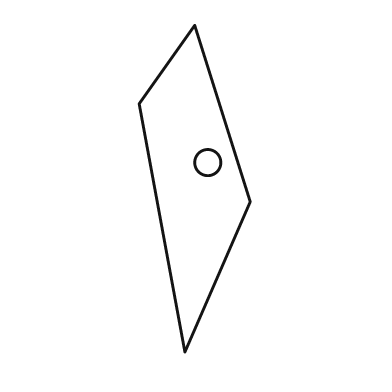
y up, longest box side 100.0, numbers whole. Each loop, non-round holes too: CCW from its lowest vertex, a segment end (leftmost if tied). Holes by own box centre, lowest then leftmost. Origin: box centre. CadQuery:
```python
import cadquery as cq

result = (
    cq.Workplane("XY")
    .moveTo(-3.0, -50.0)
    .lineTo(17.0, -4.0)
    .lineTo(0.0, 50.0)
    .lineTo(-17.0, 26.0)
    .close()
    .moveTo(4.0, 8.0)
    .circle(4.0)
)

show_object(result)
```